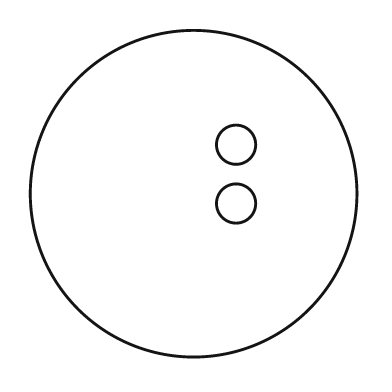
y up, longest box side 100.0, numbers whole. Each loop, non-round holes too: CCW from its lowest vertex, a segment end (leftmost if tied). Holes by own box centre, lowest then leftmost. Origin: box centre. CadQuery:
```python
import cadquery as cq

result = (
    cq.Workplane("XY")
    .moveTo(0.0, 0.0)
    .circle(50.0)
    .moveTo(13.0, -3.0)
    .circle(6.0)
    .moveTo(13.0, 15.0)
    .circle(6.0)
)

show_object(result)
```